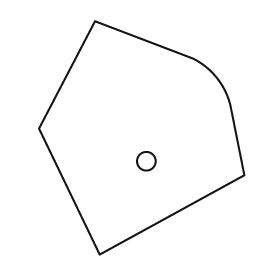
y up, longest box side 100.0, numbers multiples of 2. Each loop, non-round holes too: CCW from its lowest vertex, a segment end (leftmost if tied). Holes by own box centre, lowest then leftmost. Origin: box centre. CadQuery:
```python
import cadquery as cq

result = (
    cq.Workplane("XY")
    .moveTo(-18.0, -50.0)
    .lineTo(44.0, -16.0)
    .lineTo(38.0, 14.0)
    .threePointArc((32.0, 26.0), (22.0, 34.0))
    .lineTo(-20.0, 50.0)
    .lineTo(-44.0, 4.0)
    .close()
    .moveTo(2.0, -10.0)
    .circle(4.0)
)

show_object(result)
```